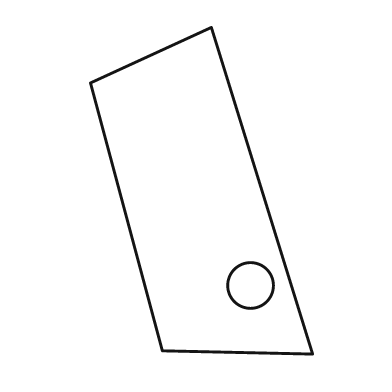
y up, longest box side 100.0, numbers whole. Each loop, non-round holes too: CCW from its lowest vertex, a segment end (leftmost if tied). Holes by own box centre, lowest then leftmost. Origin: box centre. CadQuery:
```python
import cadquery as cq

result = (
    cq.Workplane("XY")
    .moveTo(34.0, -50.0)
    .lineTo(3.0, 50.0)
    .lineTo(-34.0, 33.0)
    .lineTo(-12.0, -49.0)
    .close()
    .moveTo(15.0, -29.0)
    .circle(7.0)
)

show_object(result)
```